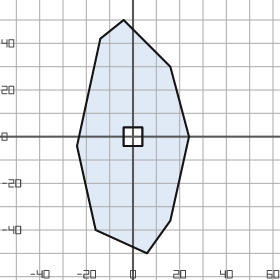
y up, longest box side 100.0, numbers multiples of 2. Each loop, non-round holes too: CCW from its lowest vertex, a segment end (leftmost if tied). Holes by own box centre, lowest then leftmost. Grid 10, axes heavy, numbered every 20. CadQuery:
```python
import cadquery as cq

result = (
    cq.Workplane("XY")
    .moveTo(6.0, -50.0)
    .lineTo(16.0, -36.0)
    .lineTo(24.0, 0.0)
    .lineTo(16.0, 30.0)
    .lineTo(-4.0, 50.0)
    .lineTo(-14.0, 42.0)
    .lineTo(-24.0, -4.0)
    .lineTo(-16.0, -40.0)
    .close()
    .moveTo(-4.0, -4.0)
    .lineTo(4.0, -4.0)
    .lineTo(4.0, 4.0)
    .lineTo(-4.0, 4.0)
    .close()
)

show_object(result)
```